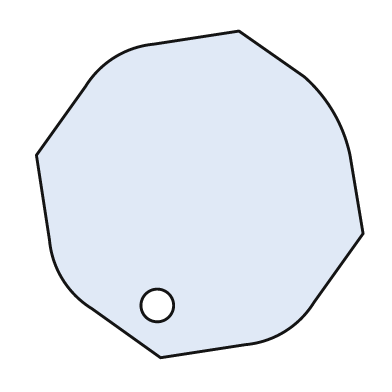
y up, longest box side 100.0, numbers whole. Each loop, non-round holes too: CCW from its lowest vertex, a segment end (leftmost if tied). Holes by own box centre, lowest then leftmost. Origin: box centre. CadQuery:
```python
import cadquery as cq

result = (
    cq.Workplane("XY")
    .moveTo(-12.0, -50.0)
    .lineTo(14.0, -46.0)
    .threePointArc((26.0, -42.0), (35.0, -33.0))
    .lineTo(50.0, -12.0)
    .lineTo(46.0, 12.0)
    .threePointArc((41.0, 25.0), (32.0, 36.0))
    .lineTo(12.0, 50.0)
    .lineTo(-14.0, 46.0)
    .threePointArc((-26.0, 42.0), (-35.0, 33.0))
    .lineTo(-50.0, 12.0)
    .lineTo(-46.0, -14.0)
    .threePointArc((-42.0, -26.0), (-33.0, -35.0))
    .close()
    .moveTo(-13.0, -34.0)
    .circle(5.0)
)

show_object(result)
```